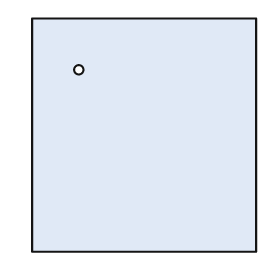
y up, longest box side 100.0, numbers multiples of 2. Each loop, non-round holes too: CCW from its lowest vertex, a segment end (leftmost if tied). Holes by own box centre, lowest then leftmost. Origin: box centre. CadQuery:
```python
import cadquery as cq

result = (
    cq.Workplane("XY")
    .moveTo(-48.0, -50.0)
    .lineTo(48.0, -50.0)
    .lineTo(48.0, 50.0)
    .lineTo(-48.0, 50.0)
    .close()
    .moveTo(-28.0, 28.0)
    .circle(2.0)
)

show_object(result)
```